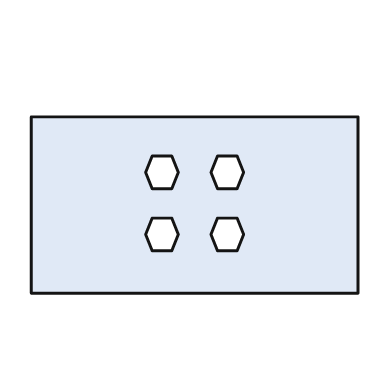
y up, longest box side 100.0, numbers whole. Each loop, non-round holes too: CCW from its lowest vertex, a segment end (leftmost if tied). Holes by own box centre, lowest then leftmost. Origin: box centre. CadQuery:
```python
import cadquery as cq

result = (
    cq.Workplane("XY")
    .moveTo(-50.0, -27.0)
    .lineTo(50.0, -27.0)
    .lineTo(50.0, 27.0)
    .lineTo(-50.0, 27.0)
    .close()
    .moveTo(-13.0, -14.0)
    .lineTo(-7.0, -14.0)
    .lineTo(-5.0, -9.0)
    .lineTo(-7.0, -4.0)
    .lineTo(-13.0, -4.0)
    .lineTo(-15.0, -9.0)
    .close()
    .moveTo(7.0, -14.0)
    .lineTo(13.0, -14.0)
    .lineTo(15.0, -9.0)
    .lineTo(13.0, -4.0)
    .lineTo(7.0, -4.0)
    .lineTo(5.0, -9.0)
    .close()
    .moveTo(-13.0, 5.0)
    .lineTo(-7.0, 5.0)
    .lineTo(-5.0, 10.0)
    .lineTo(-7.0, 15.0)
    .lineTo(-13.0, 15.0)
    .lineTo(-15.0, 10.0)
    .close()
    .moveTo(7.0, 5.0)
    .lineTo(13.0, 5.0)
    .lineTo(15.0, 10.0)
    .lineTo(13.0, 15.0)
    .lineTo(7.0, 15.0)
    .lineTo(5.0, 10.0)
    .close()
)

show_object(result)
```